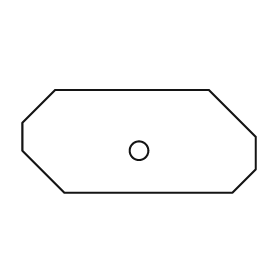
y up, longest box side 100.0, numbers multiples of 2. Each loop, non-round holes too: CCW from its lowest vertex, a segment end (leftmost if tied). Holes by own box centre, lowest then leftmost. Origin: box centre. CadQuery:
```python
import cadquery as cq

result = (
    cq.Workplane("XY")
    .moveTo(-32.0, -22.0)
    .lineTo(40.0, -22.0)
    .lineTo(50.0, -12.0)
    .lineTo(50.0, 2.0)
    .lineTo(30.0, 22.0)
    .lineTo(-36.0, 22.0)
    .lineTo(-50.0, 8.0)
    .lineTo(-50.0, -4.0)
    .close()
    .moveTo(0.0, -4.0)
    .circle(4.0)
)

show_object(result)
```